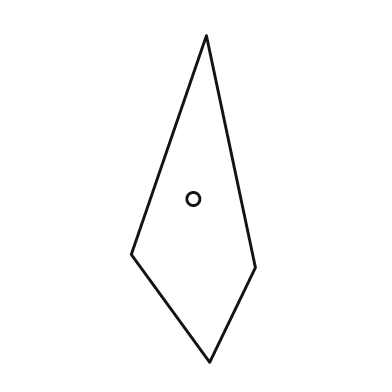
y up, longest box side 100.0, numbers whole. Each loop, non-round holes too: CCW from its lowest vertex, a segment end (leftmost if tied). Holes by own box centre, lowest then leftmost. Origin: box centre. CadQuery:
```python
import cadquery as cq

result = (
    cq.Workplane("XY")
    .moveTo(5.0, -50.0)
    .lineTo(19.0, -21.0)
    .lineTo(4.0, 50.0)
    .lineTo(-19.0, -17.0)
    .close()
    .moveTo(0.0, 0.0)
    .circle(2.0)
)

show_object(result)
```